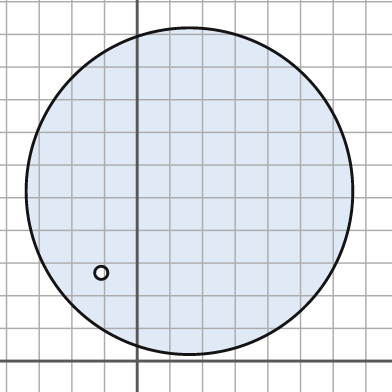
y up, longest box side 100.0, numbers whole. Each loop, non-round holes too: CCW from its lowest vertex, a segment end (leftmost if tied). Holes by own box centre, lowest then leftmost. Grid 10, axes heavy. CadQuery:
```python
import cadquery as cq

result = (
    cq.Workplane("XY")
    .moveTo(16.0, 52.0)
    .circle(50.0)
    .moveTo(-11.0, 27.0)
    .circle(2.0)
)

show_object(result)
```